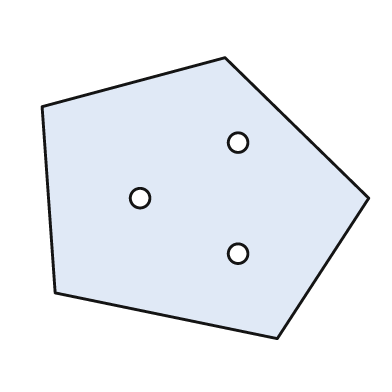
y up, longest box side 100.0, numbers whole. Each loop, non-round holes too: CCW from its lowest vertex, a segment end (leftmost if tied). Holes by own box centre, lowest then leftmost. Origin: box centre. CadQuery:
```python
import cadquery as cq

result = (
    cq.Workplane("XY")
    .moveTo(22.0, -43.0)
    .lineTo(50.0, 0.0)
    .lineTo(6.0, 43.0)
    .lineTo(-50.0, 28.0)
    .lineTo(-46.0, -29.0)
    .close()
    .moveTo(10.0, -17.0)
    .circle(3.0)
    .moveTo(-20.0, 0.0)
    .circle(3.0)
    .moveTo(10.0, 17.0)
    .circle(3.0)
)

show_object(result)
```